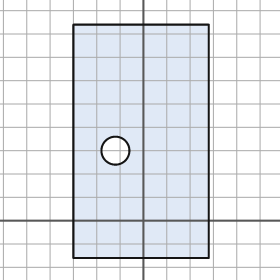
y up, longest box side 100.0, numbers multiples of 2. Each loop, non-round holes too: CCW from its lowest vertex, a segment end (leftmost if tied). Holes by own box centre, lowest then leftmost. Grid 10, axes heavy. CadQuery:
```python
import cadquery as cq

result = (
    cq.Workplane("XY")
    .moveTo(-30.0, -16.0)
    .lineTo(28.0, -16.0)
    .lineTo(28.0, 84.0)
    .lineTo(-30.0, 84.0)
    .close()
    .moveTo(-12.0, 30.0)
    .circle(6.0)
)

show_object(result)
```